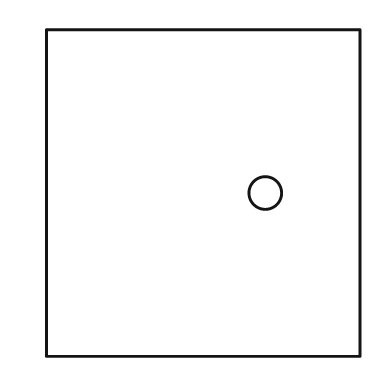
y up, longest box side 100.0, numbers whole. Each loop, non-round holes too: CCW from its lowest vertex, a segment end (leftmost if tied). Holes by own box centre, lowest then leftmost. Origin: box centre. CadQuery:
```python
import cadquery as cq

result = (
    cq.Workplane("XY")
    .moveTo(-48.0, -50.0)
    .lineTo(48.0, -50.0)
    .lineTo(48.0, 50.0)
    .lineTo(-48.0, 50.0)
    .close()
    .moveTo(19.0, 0.0)
    .circle(5.0)
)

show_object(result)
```